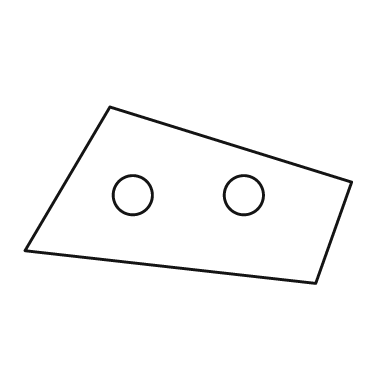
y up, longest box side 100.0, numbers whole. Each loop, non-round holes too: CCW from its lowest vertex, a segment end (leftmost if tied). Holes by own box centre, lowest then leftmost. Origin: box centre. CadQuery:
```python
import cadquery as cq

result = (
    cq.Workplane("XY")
    .moveTo(39.0, -27.0)
    .lineTo(50.0, 4.0)
    .lineTo(-24.0, 27.0)
    .lineTo(-50.0, -17.0)
    .close()
    .moveTo(-17.0, 0.0)
    .circle(6.0)
    .moveTo(17.0, 0.0)
    .circle(6.0)
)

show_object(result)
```